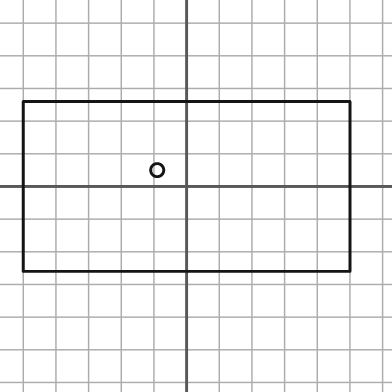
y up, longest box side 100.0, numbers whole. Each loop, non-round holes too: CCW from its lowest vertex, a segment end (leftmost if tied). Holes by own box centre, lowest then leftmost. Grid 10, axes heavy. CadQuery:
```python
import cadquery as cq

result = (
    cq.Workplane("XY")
    .moveTo(-50.0, -26.0)
    .lineTo(50.0, -26.0)
    .lineTo(50.0, 26.0)
    .lineTo(-50.0, 26.0)
    .close()
    .moveTo(-9.0, 5.0)
    .circle(2.0)
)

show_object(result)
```